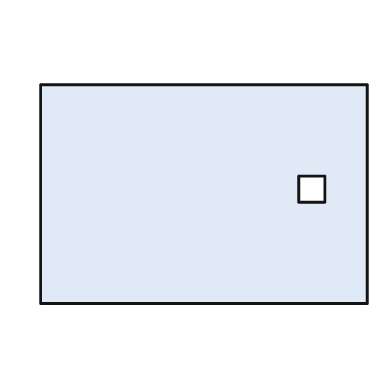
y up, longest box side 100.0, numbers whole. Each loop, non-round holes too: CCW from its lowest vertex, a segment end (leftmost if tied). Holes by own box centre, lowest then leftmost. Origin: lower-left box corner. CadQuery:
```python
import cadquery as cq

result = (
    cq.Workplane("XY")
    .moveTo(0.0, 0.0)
    .lineTo(100.0, 0.0)
    .lineTo(100.0, 67.0)
    .lineTo(0.0, 67.0)
    .close()
    .moveTo(79.0, 31.0)
    .lineTo(87.0, 31.0)
    .lineTo(87.0, 39.0)
    .lineTo(79.0, 39.0)
    .close()
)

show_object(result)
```